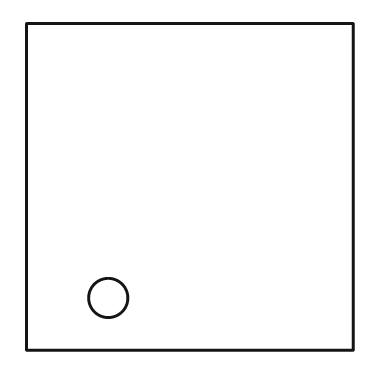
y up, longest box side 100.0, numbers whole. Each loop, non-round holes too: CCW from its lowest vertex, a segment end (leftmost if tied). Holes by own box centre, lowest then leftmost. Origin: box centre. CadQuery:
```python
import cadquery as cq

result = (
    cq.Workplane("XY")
    .moveTo(-50.0, -50.0)
    .lineTo(50.0, -50.0)
    .lineTo(50.0, 50.0)
    .lineTo(-50.0, 50.0)
    .close()
    .moveTo(-25.0, -34.0)
    .circle(6.0)
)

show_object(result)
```